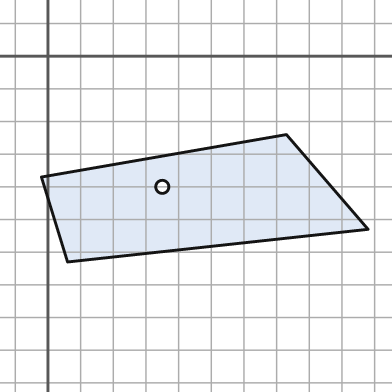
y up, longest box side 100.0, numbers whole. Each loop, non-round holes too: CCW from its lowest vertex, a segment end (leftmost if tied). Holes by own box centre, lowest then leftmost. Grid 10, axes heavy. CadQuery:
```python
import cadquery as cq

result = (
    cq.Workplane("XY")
    .moveTo(6.0, -63.0)
    .lineTo(98.0, -53.0)
    .lineTo(73.0, -24.0)
    .lineTo(-2.0, -37.0)
    .close()
    .moveTo(35.0, -40.0)
    .circle(2.0)
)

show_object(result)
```